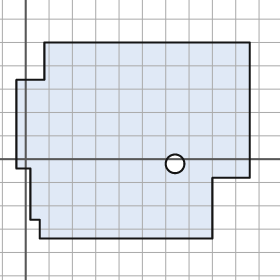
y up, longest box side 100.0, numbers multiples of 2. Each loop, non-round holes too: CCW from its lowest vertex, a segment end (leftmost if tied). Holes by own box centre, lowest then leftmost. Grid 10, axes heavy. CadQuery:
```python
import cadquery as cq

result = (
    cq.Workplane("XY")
    .moveTo(6.0, -34.0)
    .lineTo(80.0, -34.0)
    .lineTo(80.0, -8.0)
    .lineTo(96.0, -8.0)
    .lineTo(96.0, 50.0)
    .lineTo(8.0, 50.0)
    .lineTo(8.0, 34.0)
    .lineTo(-4.0, 34.0)
    .lineTo(-4.0, -4.0)
    .lineTo(2.0, -4.0)
    .lineTo(2.0, -26.0)
    .lineTo(6.0, -26.0)
    .close()
    .moveTo(64.0, -2.0)
    .circle(4.0)
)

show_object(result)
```